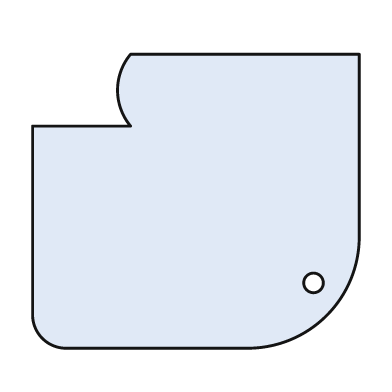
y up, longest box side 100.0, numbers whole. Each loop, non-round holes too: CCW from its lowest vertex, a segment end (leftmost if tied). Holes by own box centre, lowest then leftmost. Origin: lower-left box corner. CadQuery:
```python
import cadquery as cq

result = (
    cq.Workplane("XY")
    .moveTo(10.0, 0.0)
    .lineTo(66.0, 0.0)
    .threePointArc((90.0, 10.0), (100.0, 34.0))
    .lineTo(100.0, 90.0)
    .lineTo(30.0, 90.0)
    .threePointArc((26.0, 79.0), (30.0, 68.0))
    .lineTo(0.0, 68.0)
    .lineTo(0.0, 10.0)
    .threePointArc((3.0, 3.0), (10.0, 0.0))
    .close()
    .moveTo(86.0, 20.0)
    .circle(3.0)
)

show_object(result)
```